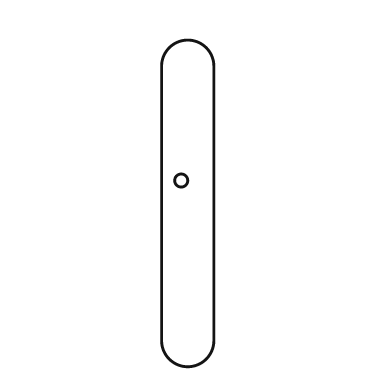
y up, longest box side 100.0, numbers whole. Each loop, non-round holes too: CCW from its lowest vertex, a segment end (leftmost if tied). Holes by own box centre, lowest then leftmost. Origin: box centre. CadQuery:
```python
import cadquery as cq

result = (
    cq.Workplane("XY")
    .moveTo(-8.0, -42.0)
    .threePointArc((0.0, -50.0), (8.0, -42.0))
    .lineTo(8.0, 42.0)
    .threePointArc((0.0, 50.0), (-8.0, 42.0))
    .close()
    .moveTo(-2.0, 7.0)
    .circle(2.0)
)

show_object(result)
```